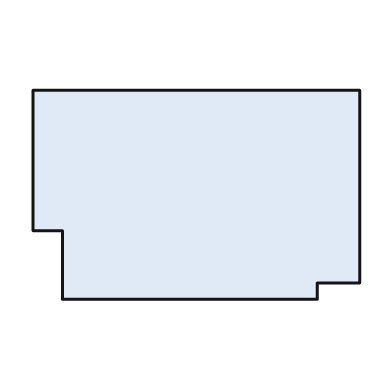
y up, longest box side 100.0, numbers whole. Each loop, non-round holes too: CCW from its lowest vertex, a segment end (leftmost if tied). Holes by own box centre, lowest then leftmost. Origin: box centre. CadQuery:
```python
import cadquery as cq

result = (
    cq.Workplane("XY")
    .moveTo(-41.0, -32.0)
    .lineTo(37.0, -32.0)
    .lineTo(37.0, -27.0)
    .lineTo(50.0, -27.0)
    .lineTo(50.0, 32.0)
    .lineTo(-50.0, 32.0)
    .lineTo(-50.0, -11.0)
    .lineTo(-41.0, -11.0)
    .close()
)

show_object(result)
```